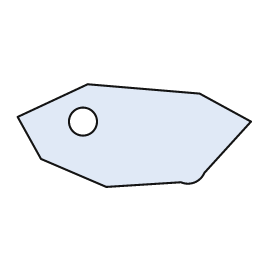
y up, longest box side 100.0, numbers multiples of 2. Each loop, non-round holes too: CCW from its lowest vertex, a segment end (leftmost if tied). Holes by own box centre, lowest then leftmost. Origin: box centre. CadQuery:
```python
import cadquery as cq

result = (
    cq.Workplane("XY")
    .moveTo(-12.0, -22.0)
    .lineTo(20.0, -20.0)
    .threePointArc((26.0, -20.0), (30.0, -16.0))
    .lineTo(50.0, 6.0)
    .lineTo(28.0, 18.0)
    .lineTo(-20.0, 22.0)
    .lineTo(-50.0, 8.0)
    .lineTo(-40.0, -10.0)
    .close()
    .moveTo(-22.0, 6.0)
    .circle(6.0)
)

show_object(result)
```